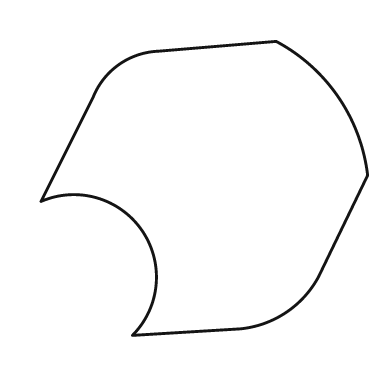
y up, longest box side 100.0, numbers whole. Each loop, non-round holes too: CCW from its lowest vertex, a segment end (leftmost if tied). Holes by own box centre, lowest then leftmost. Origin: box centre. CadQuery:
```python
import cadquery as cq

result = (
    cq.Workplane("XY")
    .moveTo(-22.0, -45.0)
    .lineTo(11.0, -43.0)
    .threePointArc((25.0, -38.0), (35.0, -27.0))
    .lineTo(50.0, 4.0)
    .threePointArc((41.0, 28.0), (22.0, 45.0))
    .lineTo(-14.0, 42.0)
    .threePointArc((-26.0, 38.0), (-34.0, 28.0))
    .lineTo(-50.0, -4.0)
    .threePointArc((-19.0, -13.0), (-22.0, -45.0))
    .close()
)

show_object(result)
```